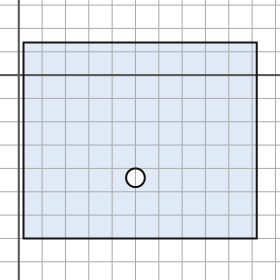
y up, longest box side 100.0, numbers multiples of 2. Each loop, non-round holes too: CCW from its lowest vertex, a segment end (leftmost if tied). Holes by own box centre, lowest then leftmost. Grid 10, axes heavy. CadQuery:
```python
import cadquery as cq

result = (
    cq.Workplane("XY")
    .moveTo(2.0, -70.0)
    .lineTo(102.0, -70.0)
    .lineTo(102.0, 14.0)
    .lineTo(2.0, 14.0)
    .close()
    .moveTo(50.0, -44.0)
    .circle(4.0)
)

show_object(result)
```